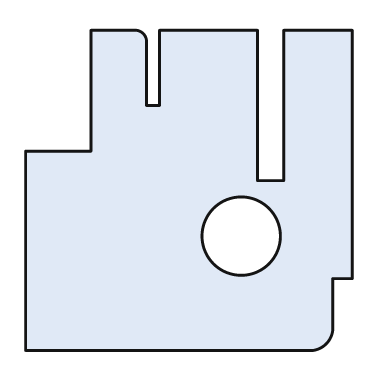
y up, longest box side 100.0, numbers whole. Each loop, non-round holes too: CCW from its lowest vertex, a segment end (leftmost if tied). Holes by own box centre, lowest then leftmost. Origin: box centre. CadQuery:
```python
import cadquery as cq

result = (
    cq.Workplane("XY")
    .moveTo(-50.0, -49.0)
    .lineTo(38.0, -49.0)
    .threePointArc((42.0, -47.0), (44.0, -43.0))
    .lineTo(44.0, -27.0)
    .lineTo(50.0, -27.0)
    .lineTo(50.0, 49.0)
    .lineTo(29.0, 49.0)
    .lineTo(29.0, 3.0)
    .lineTo(21.0, 3.0)
    .lineTo(21.0, 49.0)
    .lineTo(-9.0, 49.0)
    .lineTo(-9.0, 26.0)
    .lineTo(-13.0, 26.0)
    .lineTo(-13.0, 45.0)
    .threePointArc((-14.0, 48.0), (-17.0, 49.0))
    .lineTo(-30.0, 49.0)
    .lineTo(-30.0, 12.0)
    .lineTo(-50.0, 12.0)
    .close()
    .moveTo(16.0, -14.0)
    .circle(12.0)
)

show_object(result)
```